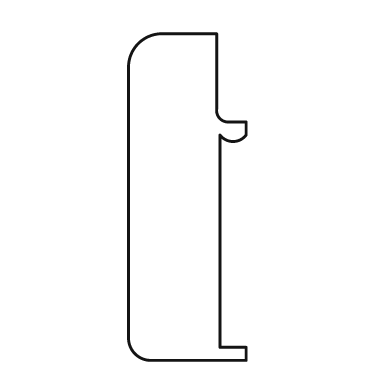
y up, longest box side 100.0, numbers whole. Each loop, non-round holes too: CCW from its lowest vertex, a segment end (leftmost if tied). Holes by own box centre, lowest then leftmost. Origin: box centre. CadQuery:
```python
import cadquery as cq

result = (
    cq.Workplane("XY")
    .moveTo(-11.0, -50.0)
    .lineTo(18.0, -50.0)
    .lineTo(18.0, -46.0)
    .lineTo(10.0, -46.0)
    .lineTo(10.0, 19.0)
    .threePointArc((14.0, 17.0), (18.0, 19.0))
    .lineTo(18.0, 23.0)
    .lineTo(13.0, 23.0)
    .threePointArc((10.0, 24.0), (9.0, 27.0))
    .lineTo(9.0, 50.0)
    .lineTo(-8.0, 50.0)
    .threePointArc((-15.0, 47.0), (-18.0, 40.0))
    .lineTo(-18.0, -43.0)
    .threePointArc((-16.0, -48.0), (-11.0, -50.0))
    .close()
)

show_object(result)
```